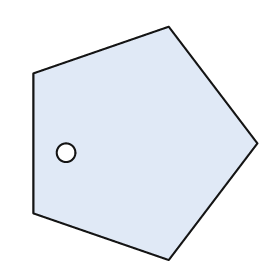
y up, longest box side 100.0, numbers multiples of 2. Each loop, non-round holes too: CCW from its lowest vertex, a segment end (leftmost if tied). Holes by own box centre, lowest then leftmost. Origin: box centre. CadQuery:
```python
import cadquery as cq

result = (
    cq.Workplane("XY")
    .moveTo(10.0, -50.0)
    .lineTo(48.0, 0.0)
    .lineTo(10.0, 50.0)
    .lineTo(-48.0, 30.0)
    .lineTo(-48.0, -30.0)
    .close()
    .moveTo(-34.0, -4.0)
    .circle(4.0)
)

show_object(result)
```